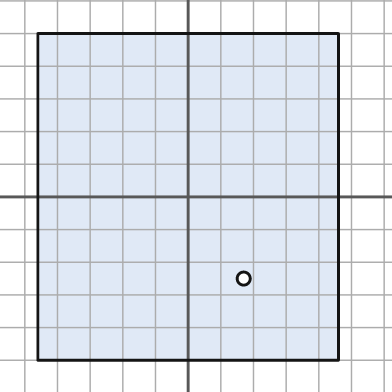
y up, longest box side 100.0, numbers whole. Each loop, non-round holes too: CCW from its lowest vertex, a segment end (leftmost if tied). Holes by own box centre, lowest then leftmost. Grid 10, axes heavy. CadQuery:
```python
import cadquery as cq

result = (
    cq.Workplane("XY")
    .moveTo(-46.0, -50.0)
    .lineTo(46.0, -50.0)
    .lineTo(46.0, 50.0)
    .lineTo(-46.0, 50.0)
    .close()
    .moveTo(17.0, -25.0)
    .circle(2.0)
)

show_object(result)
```